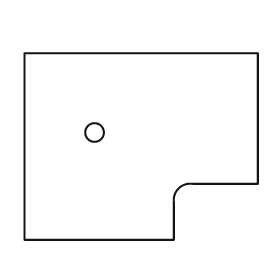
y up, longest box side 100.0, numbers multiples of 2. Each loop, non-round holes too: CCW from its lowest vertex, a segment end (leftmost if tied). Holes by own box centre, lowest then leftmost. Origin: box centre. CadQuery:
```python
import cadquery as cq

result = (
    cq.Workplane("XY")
    .moveTo(-50.0, -40.0)
    .lineTo(14.0, -40.0)
    .lineTo(14.0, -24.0)
    .threePointArc((16.0, -18.0), (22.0, -16.0))
    .lineTo(50.0, -16.0)
    .lineTo(50.0, 40.0)
    .lineTo(-50.0, 40.0)
    .close()
    .moveTo(-20.0, 6.0)
    .circle(4.0)
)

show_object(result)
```